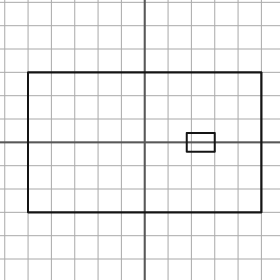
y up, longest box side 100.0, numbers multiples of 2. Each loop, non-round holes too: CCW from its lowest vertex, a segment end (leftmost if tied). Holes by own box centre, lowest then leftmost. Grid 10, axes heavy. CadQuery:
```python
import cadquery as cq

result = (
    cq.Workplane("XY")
    .moveTo(-50.0, -30.0)
    .lineTo(50.0, -30.0)
    .lineTo(50.0, 30.0)
    .lineTo(-50.0, 30.0)
    .close()
    .moveTo(18.0, -4.0)
    .lineTo(30.0, -4.0)
    .lineTo(30.0, 4.0)
    .lineTo(18.0, 4.0)
    .close()
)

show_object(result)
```